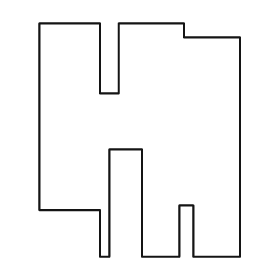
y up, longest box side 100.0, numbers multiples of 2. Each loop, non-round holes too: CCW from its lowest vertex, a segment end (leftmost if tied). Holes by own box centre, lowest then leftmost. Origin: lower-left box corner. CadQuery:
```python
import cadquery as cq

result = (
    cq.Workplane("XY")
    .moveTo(26.0, 0.0)
    .lineTo(30.0, 0.0)
    .lineTo(30.0, 46.0)
    .lineTo(44.0, 46.0)
    .lineTo(44.0, 0.0)
    .lineTo(60.0, 0.0)
    .lineTo(60.0, 22.0)
    .lineTo(66.0, 22.0)
    .lineTo(66.0, 0.0)
    .lineTo(86.0, 0.0)
    .lineTo(86.0, 94.0)
    .lineTo(62.0, 94.0)
    .lineTo(62.0, 100.0)
    .lineTo(34.0, 100.0)
    .lineTo(34.0, 70.0)
    .lineTo(26.0, 70.0)
    .lineTo(26.0, 100.0)
    .lineTo(0.0, 100.0)
    .lineTo(0.0, 20.0)
    .lineTo(26.0, 20.0)
    .close()
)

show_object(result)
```